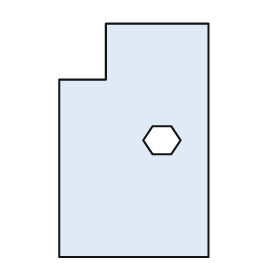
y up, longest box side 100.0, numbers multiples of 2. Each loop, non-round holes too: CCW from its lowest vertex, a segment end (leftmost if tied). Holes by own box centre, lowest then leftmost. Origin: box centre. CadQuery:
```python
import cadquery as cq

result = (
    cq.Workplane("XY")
    .moveTo(-32.0, -50.0)
    .lineTo(32.0, -50.0)
    .lineTo(32.0, 50.0)
    .lineTo(-12.0, 50.0)
    .lineTo(-12.0, 26.0)
    .lineTo(-32.0, 26.0)
    .close()
    .moveTo(8.0, -6.0)
    .lineTo(16.0, -6.0)
    .lineTo(20.0, 0.0)
    .lineTo(16.0, 6.0)
    .lineTo(8.0, 6.0)
    .lineTo(4.0, 0.0)
    .close()
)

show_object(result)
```